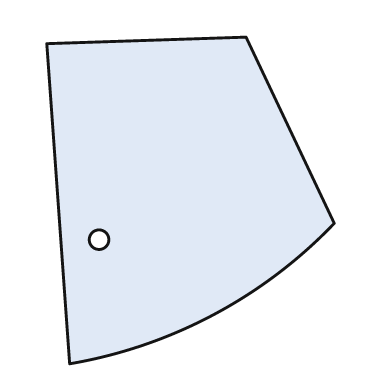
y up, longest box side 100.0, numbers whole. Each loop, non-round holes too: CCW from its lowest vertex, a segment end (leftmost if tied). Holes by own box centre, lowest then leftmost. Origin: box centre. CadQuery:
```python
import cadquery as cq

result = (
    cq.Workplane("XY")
    .moveTo(-37.0, -50.0)
    .threePointArc((7.0, -35.0), (44.0, -7.0))
    .lineTo(17.0, 50.0)
    .lineTo(-44.0, 48.0)
    .close()
    .moveTo(-28.0, -12.0)
    .circle(3.0)
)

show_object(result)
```